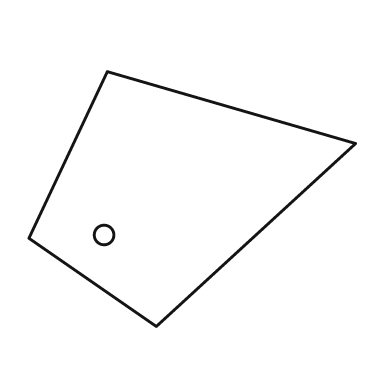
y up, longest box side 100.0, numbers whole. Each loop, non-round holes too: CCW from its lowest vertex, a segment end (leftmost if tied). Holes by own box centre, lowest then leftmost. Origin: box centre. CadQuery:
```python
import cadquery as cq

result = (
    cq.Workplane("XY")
    .moveTo(-11.0, -39.0)
    .lineTo(50.0, 17.0)
    .lineTo(-26.0, 39.0)
    .lineTo(-50.0, -12.0)
    .close()
    .moveTo(-27.0, -11.0)
    .circle(3.0)
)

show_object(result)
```